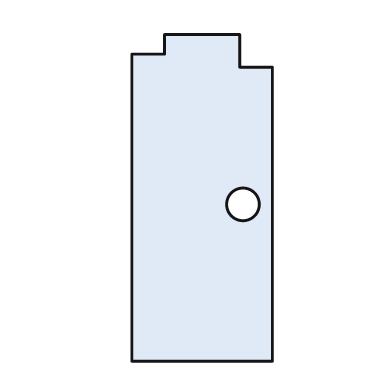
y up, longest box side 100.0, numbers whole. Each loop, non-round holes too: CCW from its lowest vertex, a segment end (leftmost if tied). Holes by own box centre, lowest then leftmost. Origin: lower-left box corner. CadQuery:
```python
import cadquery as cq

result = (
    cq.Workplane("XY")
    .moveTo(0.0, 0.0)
    .lineTo(43.0, 0.0)
    .lineTo(43.0, 90.0)
    .lineTo(33.0, 90.0)
    .lineTo(33.0, 100.0)
    .lineTo(10.0, 100.0)
    .lineTo(10.0, 94.0)
    .lineTo(0.0, 94.0)
    .close()
    .moveTo(34.0, 48.0)
    .circle(5.0)
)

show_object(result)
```